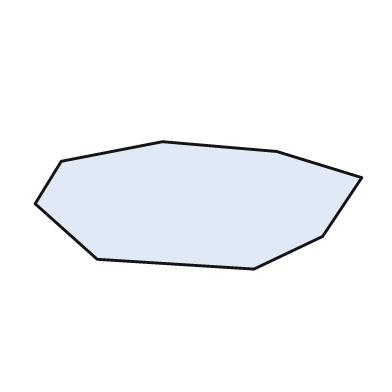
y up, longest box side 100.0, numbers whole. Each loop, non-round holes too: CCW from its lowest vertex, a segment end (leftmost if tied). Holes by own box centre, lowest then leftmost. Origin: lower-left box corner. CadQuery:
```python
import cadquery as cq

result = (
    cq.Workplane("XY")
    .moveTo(67.0, 0.0)
    .lineTo(88.0, 10.0)
    .lineTo(100.0, 28.0)
    .lineTo(74.0, 36.0)
    .lineTo(39.0, 39.0)
    .lineTo(8.0, 33.0)
    .lineTo(0.0, 20.0)
    .lineTo(19.0, 3.0)
    .close()
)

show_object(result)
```